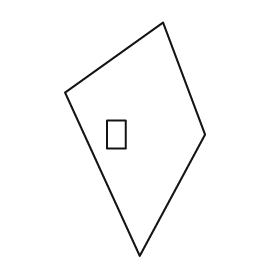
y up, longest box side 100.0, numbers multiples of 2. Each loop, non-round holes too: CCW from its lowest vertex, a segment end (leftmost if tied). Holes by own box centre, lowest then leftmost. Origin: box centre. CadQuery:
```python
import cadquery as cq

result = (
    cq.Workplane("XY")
    .moveTo(2.0, -50.0)
    .lineTo(30.0, 2.0)
    .lineTo(12.0, 50.0)
    .lineTo(-30.0, 20.0)
    .close()
    .moveTo(-12.0, -4.0)
    .lineTo(-4.0, -4.0)
    .lineTo(-4.0, 8.0)
    .lineTo(-12.0, 8.0)
    .close()
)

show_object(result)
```